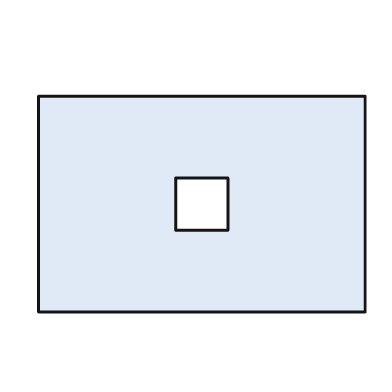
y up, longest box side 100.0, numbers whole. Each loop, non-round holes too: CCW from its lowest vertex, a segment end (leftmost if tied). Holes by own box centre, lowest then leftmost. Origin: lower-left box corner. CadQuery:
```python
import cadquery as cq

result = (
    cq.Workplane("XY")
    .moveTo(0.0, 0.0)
    .lineTo(100.0, 0.0)
    .lineTo(100.0, 66.0)
    .lineTo(0.0, 66.0)
    .close()
    .moveTo(42.0, 25.0)
    .lineTo(58.0, 25.0)
    .lineTo(58.0, 41.0)
    .lineTo(42.0, 41.0)
    .close()
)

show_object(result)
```